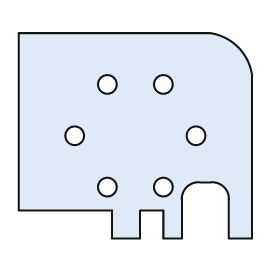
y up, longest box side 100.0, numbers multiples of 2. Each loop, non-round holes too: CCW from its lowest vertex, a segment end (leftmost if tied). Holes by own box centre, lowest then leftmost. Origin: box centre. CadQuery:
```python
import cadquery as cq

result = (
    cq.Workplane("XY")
    .moveTo(-10.0, -44.0)
    .lineTo(2.0, -44.0)
    .lineTo(2.0, -32.0)
    .lineTo(12.0, -32.0)
    .lineTo(12.0, -44.0)
    .lineTo(20.0, -44.0)
    .lineTo(20.0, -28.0)
    .threePointArc((22.0, -22.0), (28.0, -20.0))
    .lineTo(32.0, -20.0)
    .threePointArc((38.0, -22.0), (40.0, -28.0))
    .lineTo(40.0, -44.0)
    .lineTo(50.0, -44.0)
    .lineTo(50.0, 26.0)
    .threePointArc((44.0, 38.0), (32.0, 44.0))
    .lineTo(-50.0, 44.0)
    .lineTo(-50.0, -32.0)
    .lineTo(-10.0, -32.0)
    .close()
    .moveTo(-12.0, -22.0)
    .circle(4.0)
    .moveTo(12.0, -22.0)
    .circle(4.0)
    .moveTo(-26.0, 0.0)
    .circle(4.0)
    .moveTo(26.0, 0.0)
    .circle(4.0)
    .moveTo(-12.0, 22.0)
    .circle(4.0)
    .moveTo(12.0, 22.0)
    .circle(4.0)
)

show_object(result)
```